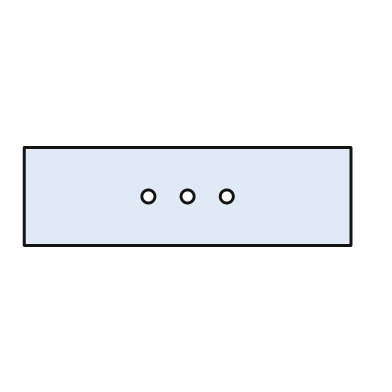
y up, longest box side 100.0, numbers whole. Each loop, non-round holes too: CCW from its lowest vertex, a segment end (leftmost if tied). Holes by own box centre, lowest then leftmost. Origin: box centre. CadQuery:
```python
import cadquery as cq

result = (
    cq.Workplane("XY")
    .moveTo(-50.0, -15.0)
    .lineTo(50.0, -15.0)
    .lineTo(50.0, 15.0)
    .lineTo(-50.0, 15.0)
    .close()
    .moveTo(-12.0, 0.0)
    .circle(2.0)
    .moveTo(0.0, 0.0)
    .circle(2.0)
    .moveTo(12.0, 0.0)
    .circle(2.0)
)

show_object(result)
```